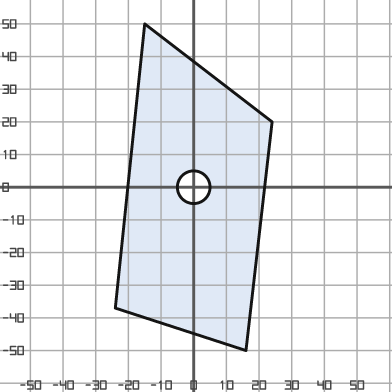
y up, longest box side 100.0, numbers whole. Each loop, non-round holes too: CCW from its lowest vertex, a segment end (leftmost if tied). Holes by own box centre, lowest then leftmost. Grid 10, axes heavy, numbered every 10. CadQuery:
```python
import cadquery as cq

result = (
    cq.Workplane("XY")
    .moveTo(16.0, -50.0)
    .lineTo(24.0, 20.0)
    .lineTo(-15.0, 50.0)
    .lineTo(-24.0, -37.0)
    .close()
    .moveTo(0.0, 0.0)
    .circle(5.0)
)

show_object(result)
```